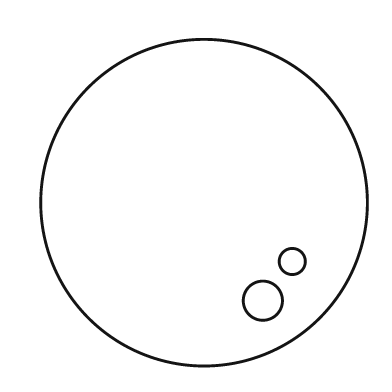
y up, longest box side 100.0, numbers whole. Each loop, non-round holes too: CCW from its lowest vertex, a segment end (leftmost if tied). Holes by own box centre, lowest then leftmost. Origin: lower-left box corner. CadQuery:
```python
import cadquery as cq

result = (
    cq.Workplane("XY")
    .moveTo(50.0, 50.0)
    .circle(50.0)
    .moveTo(68.0, 20.0)
    .circle(6.0)
    .moveTo(77.0, 32.0)
    .circle(4.0)
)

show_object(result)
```